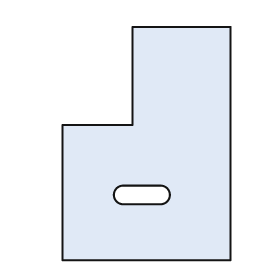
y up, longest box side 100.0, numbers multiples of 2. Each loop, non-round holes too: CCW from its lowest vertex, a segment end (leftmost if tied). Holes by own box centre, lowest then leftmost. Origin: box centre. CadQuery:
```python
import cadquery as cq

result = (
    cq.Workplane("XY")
    .moveTo(-36.0, -50.0)
    .lineTo(36.0, -50.0)
    .lineTo(36.0, 50.0)
    .lineTo(-6.0, 50.0)
    .lineTo(-6.0, 8.0)
    .lineTo(-36.0, 8.0)
    .close()
    .moveTo(-10.0, -26.0)
    .lineTo(6.0, -26.0)
    .threePointArc((10.0, -22.0), (6.0, -18.0))
    .lineTo(-10.0, -18.0)
    .threePointArc((-14.0, -22.0), (-10.0, -26.0))
    .close()
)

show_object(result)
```